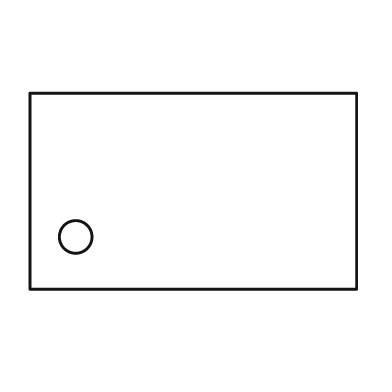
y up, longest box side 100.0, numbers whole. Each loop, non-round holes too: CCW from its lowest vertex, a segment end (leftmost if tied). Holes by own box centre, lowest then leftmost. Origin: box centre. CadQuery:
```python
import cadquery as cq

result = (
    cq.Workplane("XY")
    .moveTo(-50.0, -30.0)
    .lineTo(50.0, -30.0)
    .lineTo(50.0, 30.0)
    .lineTo(-50.0, 30.0)
    .close()
    .moveTo(-36.0, -14.0)
    .circle(5.0)
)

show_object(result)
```